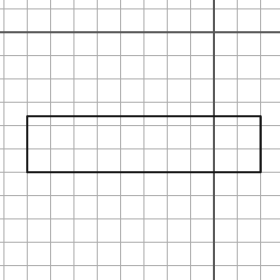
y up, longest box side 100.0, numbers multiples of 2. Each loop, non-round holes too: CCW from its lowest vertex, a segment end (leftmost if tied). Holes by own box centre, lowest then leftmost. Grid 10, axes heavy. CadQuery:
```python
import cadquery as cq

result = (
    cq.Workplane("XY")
    .moveTo(-80.0, -60.0)
    .lineTo(20.0, -60.0)
    .lineTo(20.0, -36.0)
    .lineTo(-80.0, -36.0)
    .close()
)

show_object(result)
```